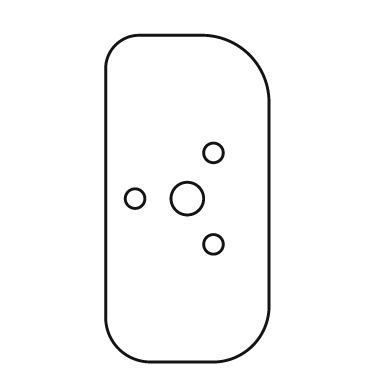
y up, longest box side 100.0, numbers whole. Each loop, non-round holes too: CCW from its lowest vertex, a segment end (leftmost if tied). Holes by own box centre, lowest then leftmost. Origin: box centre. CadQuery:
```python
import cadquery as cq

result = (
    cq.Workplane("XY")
    .moveTo(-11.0, -50.0)
    .lineTo(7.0, -50.0)
    .threePointArc((20.0, -45.0), (25.0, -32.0))
    .lineTo(25.0, 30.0)
    .threePointArc((19.0, 44.0), (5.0, 50.0))
    .lineTo(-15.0, 50.0)
    .threePointArc((-22.0, 47.0), (-25.0, 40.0))
    .lineTo(-25.0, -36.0)
    .threePointArc((-21.0, -46.0), (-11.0, -50.0))
    .close()
    .moveTo(8.0, -14.0)
    .circle(3.0)
    .moveTo(-16.0, 0.0)
    .circle(3.0)
    .moveTo(0.0, 0.0)
    .circle(5.0)
    .moveTo(8.0, 14.0)
    .circle(3.0)
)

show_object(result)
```